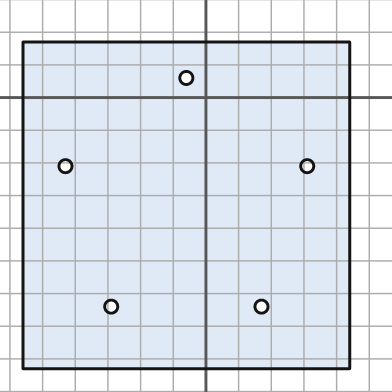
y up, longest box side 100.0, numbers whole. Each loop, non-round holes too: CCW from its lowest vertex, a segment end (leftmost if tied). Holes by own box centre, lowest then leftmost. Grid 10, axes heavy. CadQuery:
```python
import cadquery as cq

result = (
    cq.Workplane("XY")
    .moveTo(-56.0, -83.0)
    .lineTo(44.0, -83.0)
    .lineTo(44.0, 17.0)
    .lineTo(-56.0, 17.0)
    .close()
    .moveTo(-29.0, -64.0)
    .circle(2.0)
    .moveTo(17.0, -64.0)
    .circle(2.0)
    .moveTo(-43.0, -21.0)
    .circle(2.0)
    .moveTo(31.0, -21.0)
    .circle(2.0)
    .moveTo(-6.0, 6.0)
    .circle(2.0)
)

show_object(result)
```